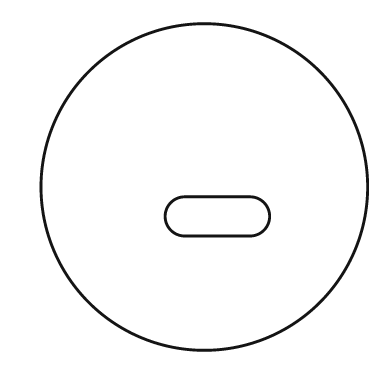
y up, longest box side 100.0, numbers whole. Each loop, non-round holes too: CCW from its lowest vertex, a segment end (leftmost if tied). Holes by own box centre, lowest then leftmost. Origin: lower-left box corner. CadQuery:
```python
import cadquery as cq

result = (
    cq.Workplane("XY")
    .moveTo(50.0, 50.0)
    .circle(50.0)
    .moveTo(44.0, 35.0)
    .lineTo(64.0, 35.0)
    .threePointArc((70.0, 41.0), (64.0, 47.0))
    .lineTo(44.0, 47.0)
    .threePointArc((38.0, 41.0), (44.0, 35.0))
    .close()
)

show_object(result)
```